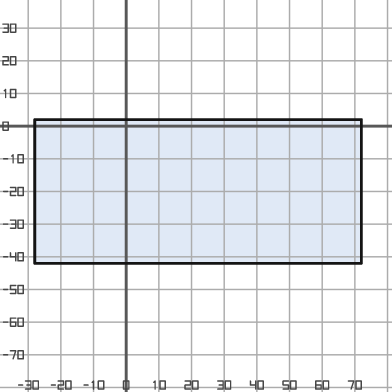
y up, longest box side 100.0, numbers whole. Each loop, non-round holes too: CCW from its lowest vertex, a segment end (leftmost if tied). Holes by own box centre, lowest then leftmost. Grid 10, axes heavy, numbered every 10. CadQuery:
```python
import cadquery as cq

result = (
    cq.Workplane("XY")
    .moveTo(-28.0, -42.0)
    .lineTo(72.0, -42.0)
    .lineTo(72.0, 2.0)
    .lineTo(-28.0, 2.0)
    .close()
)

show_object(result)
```